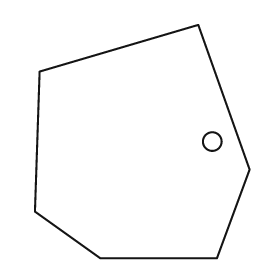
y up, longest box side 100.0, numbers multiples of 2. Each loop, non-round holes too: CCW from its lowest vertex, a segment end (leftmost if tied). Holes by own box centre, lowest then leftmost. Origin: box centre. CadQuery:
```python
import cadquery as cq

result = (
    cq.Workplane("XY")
    .moveTo(-18.0, -50.0)
    .lineTo(32.0, -50.0)
    .lineTo(46.0, -12.0)
    .lineTo(24.0, 50.0)
    .lineTo(-44.0, 30.0)
    .lineTo(-46.0, -30.0)
    .close()
    .moveTo(30.0, 0.0)
    .circle(4.0)
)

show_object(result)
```